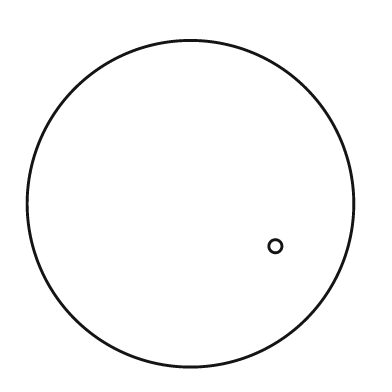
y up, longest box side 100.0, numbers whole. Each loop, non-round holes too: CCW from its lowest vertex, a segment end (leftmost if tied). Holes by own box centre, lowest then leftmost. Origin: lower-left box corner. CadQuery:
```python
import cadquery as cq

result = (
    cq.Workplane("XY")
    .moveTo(50.0, 50.0)
    .circle(50.0)
    .moveTo(76.0, 37.0)
    .circle(2.0)
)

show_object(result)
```